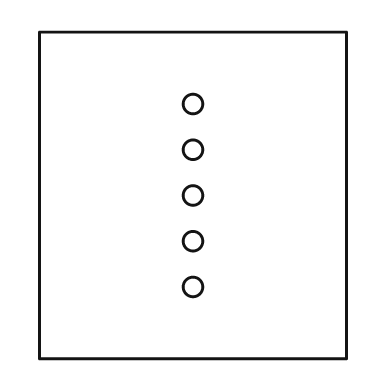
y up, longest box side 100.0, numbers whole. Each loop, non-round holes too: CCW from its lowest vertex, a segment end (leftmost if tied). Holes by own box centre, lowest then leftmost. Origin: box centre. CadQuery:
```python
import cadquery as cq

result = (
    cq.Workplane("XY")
    .moveTo(-47.0, -50.0)
    .lineTo(47.0, -50.0)
    .lineTo(47.0, 50.0)
    .lineTo(-47.0, 50.0)
    .close()
    .moveTo(0.0, -28.0)
    .circle(3.0)
    .moveTo(0.0, -14.0)
    .circle(3.0)
    .moveTo(0.0, 0.0)
    .circle(3.0)
    .moveTo(0.0, 14.0)
    .circle(3.0)
    .moveTo(0.0, 28.0)
    .circle(3.0)
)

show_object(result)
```